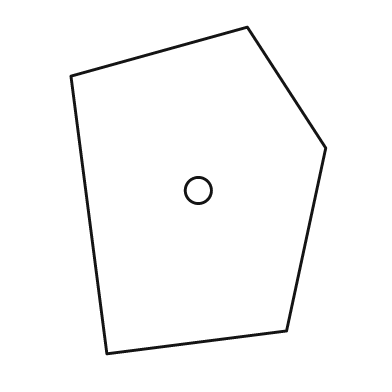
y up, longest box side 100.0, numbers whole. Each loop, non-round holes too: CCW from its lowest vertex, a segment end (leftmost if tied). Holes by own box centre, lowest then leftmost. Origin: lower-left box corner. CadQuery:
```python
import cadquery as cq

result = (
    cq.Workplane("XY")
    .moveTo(11.0, 0.0)
    .lineTo(66.0, 7.0)
    .lineTo(78.0, 63.0)
    .lineTo(54.0, 100.0)
    .lineTo(0.0, 85.0)
    .close()
    .moveTo(39.0, 50.0)
    .circle(4.0)
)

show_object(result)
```